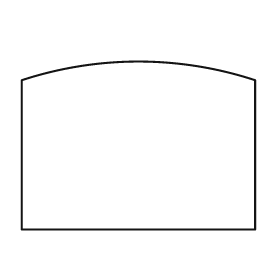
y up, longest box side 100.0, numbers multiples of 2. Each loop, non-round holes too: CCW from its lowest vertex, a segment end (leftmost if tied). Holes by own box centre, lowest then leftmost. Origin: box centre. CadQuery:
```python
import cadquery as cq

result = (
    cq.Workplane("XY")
    .moveTo(-50.0, -36.0)
    .lineTo(50.0, -36.0)
    .lineTo(50.0, 28.0)
    .threePointArc((0.0, 36.0), (-50.0, 28.0))
    .close()
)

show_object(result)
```